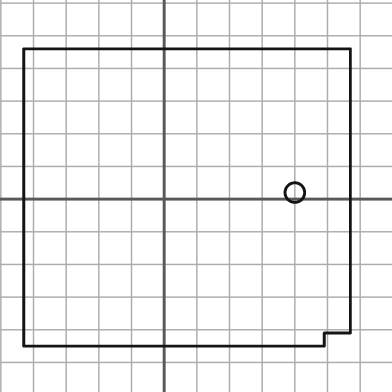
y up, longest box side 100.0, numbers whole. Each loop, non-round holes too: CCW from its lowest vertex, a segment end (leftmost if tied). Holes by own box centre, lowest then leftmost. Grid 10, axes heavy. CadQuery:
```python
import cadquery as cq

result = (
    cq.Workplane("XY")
    .moveTo(-43.0, -45.0)
    .lineTo(49.0, -45.0)
    .lineTo(49.0, -41.0)
    .lineTo(57.0, -41.0)
    .lineTo(57.0, 46.0)
    .lineTo(-43.0, 46.0)
    .close()
    .moveTo(40.0, 2.0)
    .circle(3.0)
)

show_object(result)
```